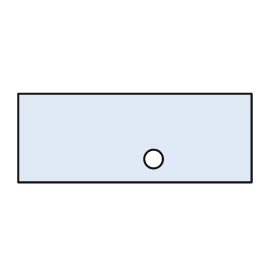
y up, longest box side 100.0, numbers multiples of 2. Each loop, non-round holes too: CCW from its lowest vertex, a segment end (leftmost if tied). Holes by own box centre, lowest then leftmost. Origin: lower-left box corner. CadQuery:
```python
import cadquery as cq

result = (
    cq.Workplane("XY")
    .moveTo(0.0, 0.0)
    .lineTo(100.0, 0.0)
    .lineTo(100.0, 38.0)
    .lineTo(0.0, 38.0)
    .close()
    .moveTo(58.0, 10.0)
    .circle(4.0)
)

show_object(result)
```